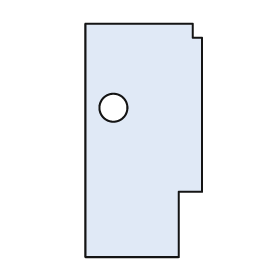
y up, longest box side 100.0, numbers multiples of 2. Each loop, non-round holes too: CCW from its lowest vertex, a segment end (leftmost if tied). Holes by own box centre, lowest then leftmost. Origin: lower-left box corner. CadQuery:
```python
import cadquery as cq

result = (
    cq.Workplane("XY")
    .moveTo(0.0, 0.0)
    .lineTo(40.0, 0.0)
    .lineTo(40.0, 28.0)
    .lineTo(50.0, 28.0)
    .lineTo(50.0, 94.0)
    .lineTo(46.0, 94.0)
    .lineTo(46.0, 100.0)
    .lineTo(0.0, 100.0)
    .close()
    .moveTo(12.0, 64.0)
    .circle(6.0)
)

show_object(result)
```